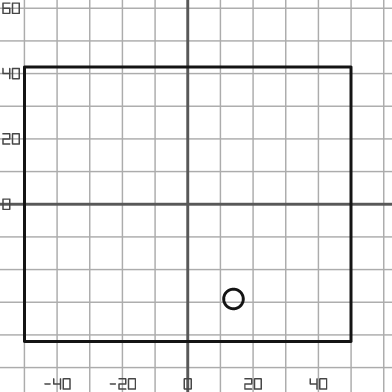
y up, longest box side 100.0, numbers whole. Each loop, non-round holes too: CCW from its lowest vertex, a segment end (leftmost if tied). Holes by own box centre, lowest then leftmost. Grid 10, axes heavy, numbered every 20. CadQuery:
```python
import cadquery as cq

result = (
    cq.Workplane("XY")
    .moveTo(-50.0, -42.0)
    .lineTo(50.0, -42.0)
    .lineTo(50.0, 42.0)
    .lineTo(-50.0, 42.0)
    .close()
    .moveTo(14.0, -29.0)
    .circle(3.0)
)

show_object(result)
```